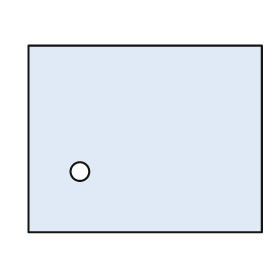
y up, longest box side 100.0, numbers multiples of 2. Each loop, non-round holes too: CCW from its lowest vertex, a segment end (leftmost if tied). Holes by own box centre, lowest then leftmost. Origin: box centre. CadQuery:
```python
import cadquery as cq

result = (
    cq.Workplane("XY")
    .moveTo(-50.0, -40.0)
    .lineTo(50.0, -40.0)
    .lineTo(50.0, 40.0)
    .lineTo(-50.0, 40.0)
    .close()
    .moveTo(-28.0, -14.0)
    .circle(4.0)
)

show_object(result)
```